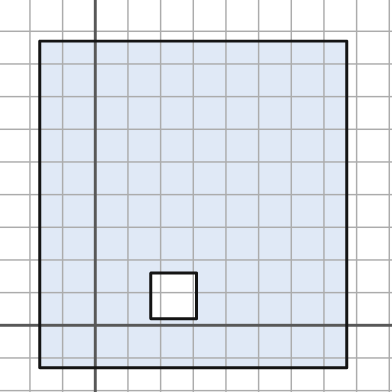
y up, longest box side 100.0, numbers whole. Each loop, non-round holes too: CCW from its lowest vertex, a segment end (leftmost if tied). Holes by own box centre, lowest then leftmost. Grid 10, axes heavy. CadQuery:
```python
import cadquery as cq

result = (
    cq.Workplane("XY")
    .moveTo(-17.0, -13.0)
    .lineTo(77.0, -13.0)
    .lineTo(77.0, 87.0)
    .lineTo(-17.0, 87.0)
    .close()
    .moveTo(17.0, 2.0)
    .lineTo(31.0, 2.0)
    .lineTo(31.0, 16.0)
    .lineTo(17.0, 16.0)
    .close()
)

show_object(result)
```